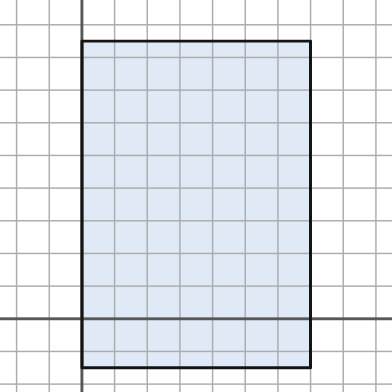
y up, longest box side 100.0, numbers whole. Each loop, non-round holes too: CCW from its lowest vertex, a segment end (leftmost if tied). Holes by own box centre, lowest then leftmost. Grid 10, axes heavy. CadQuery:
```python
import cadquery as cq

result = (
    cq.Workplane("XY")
    .moveTo(0.0, -15.0)
    .lineTo(70.0, -15.0)
    .lineTo(70.0, 85.0)
    .lineTo(0.0, 85.0)
    .close()
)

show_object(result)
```